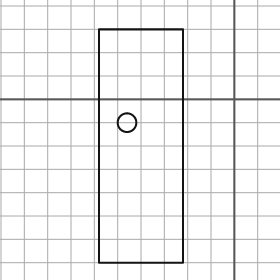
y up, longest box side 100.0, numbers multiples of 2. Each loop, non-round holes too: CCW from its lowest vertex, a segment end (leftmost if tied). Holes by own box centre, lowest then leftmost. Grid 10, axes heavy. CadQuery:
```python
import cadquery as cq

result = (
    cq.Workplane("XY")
    .moveTo(-58.0, -70.0)
    .lineTo(-22.0, -70.0)
    .lineTo(-22.0, 30.0)
    .lineTo(-58.0, 30.0)
    .close()
    .moveTo(-46.0, -10.0)
    .circle(4.0)
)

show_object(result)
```